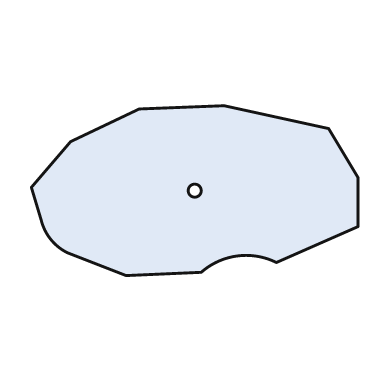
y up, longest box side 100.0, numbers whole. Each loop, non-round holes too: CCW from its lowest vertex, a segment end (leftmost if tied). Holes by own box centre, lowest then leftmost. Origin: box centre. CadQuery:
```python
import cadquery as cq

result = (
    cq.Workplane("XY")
    .moveTo(-21.0, -26.0)
    .lineTo(2.0, -25.0)
    .threePointArc((13.0, -20.0), (25.0, -22.0))
    .lineTo(50.0, -11.0)
    .lineTo(50.0, 4.0)
    .lineTo(41.0, 19.0)
    .lineTo(9.0, 26.0)
    .lineTo(-17.0, 25.0)
    .lineTo(-38.0, 15.0)
    .lineTo(-50.0, 1.0)
    .lineTo(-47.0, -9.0)
    .threePointArc((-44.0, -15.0), (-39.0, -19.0))
    .close()
    .moveTo(0.0, 0.0)
    .circle(2.0)
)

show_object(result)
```